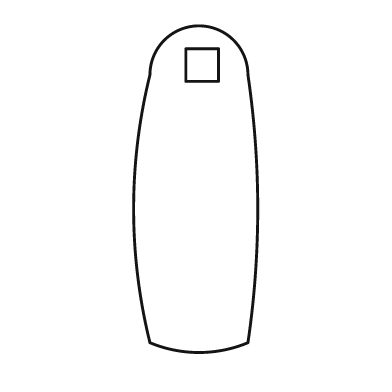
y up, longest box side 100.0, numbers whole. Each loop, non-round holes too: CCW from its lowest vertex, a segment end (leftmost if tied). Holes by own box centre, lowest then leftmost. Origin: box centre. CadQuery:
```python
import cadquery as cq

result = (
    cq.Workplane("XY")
    .moveTo(-14.0, -47.0)
    .threePointArc((1.0, -50.0), (16.0, -47.0))
    .threePointArc((19.0, -6.0), (16.0, 35.0))
    .threePointArc((1.0, 50.0), (-14.0, 35.0))
    .threePointArc((-19.0, -6.0), (-14.0, -47.0))
    .close()
    .moveTo(-3.0, 33.0)
    .lineTo(7.0, 33.0)
    .lineTo(7.0, 43.0)
    .lineTo(-3.0, 43.0)
    .close()
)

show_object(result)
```